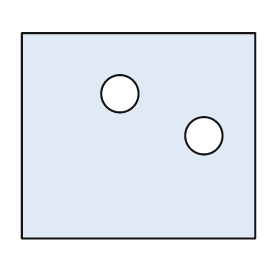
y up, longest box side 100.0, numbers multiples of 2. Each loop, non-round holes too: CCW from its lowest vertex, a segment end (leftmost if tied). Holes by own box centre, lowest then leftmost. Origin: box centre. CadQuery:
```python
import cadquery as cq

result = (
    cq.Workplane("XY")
    .moveTo(-50.0, -44.0)
    .lineTo(50.0, -44.0)
    .lineTo(50.0, 44.0)
    .lineTo(-50.0, 44.0)
    .close()
    .moveTo(28.0, 0.0)
    .circle(8.0)
    .moveTo(-8.0, 18.0)
    .circle(8.0)
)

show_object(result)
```